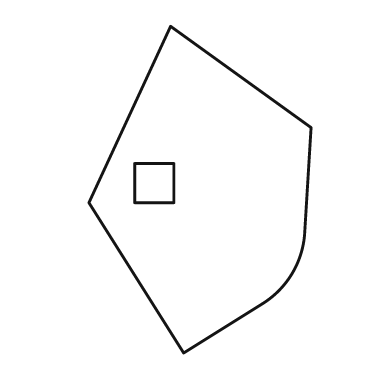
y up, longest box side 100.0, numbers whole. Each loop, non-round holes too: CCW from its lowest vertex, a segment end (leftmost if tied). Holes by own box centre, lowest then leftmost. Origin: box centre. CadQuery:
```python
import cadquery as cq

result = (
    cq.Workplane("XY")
    .moveTo(-5.0, -50.0)
    .lineTo(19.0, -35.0)
    .threePointArc((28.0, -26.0), (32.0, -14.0))
    .lineTo(34.0, 19.0)
    .lineTo(-9.0, 50.0)
    .lineTo(-34.0, -4.0)
    .close()
    .moveTo(-20.0, -4.0)
    .lineTo(-8.0, -4.0)
    .lineTo(-8.0, 8.0)
    .lineTo(-20.0, 8.0)
    .close()
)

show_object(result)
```